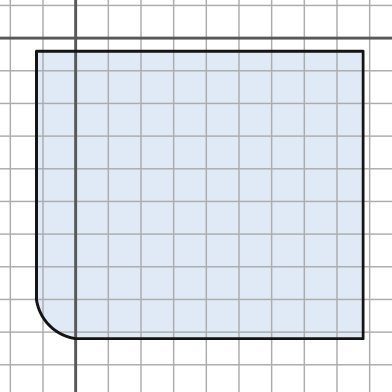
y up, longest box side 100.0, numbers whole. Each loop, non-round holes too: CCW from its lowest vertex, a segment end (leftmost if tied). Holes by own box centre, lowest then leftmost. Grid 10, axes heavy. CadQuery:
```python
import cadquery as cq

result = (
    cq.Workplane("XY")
    .moveTo(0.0, -92.0)
    .lineTo(88.0, -92.0)
    .lineTo(88.0, -4.0)
    .lineTo(-12.0, -4.0)
    .lineTo(-12.0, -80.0)
    .threePointArc((-8.0, -88.0), (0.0, -92.0))
    .close()
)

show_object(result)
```